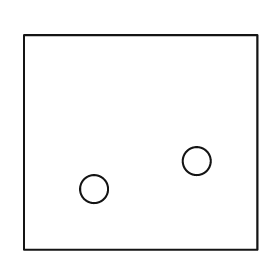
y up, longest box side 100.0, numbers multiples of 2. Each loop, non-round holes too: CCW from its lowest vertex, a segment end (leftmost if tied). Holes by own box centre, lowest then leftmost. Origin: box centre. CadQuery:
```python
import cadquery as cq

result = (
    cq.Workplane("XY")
    .moveTo(-50.0, -46.0)
    .lineTo(50.0, -46.0)
    .lineTo(50.0, 46.0)
    .lineTo(-50.0, 46.0)
    .close()
    .moveTo(-20.0, -20.0)
    .circle(6.0)
    .moveTo(24.0, -8.0)
    .circle(6.0)
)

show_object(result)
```